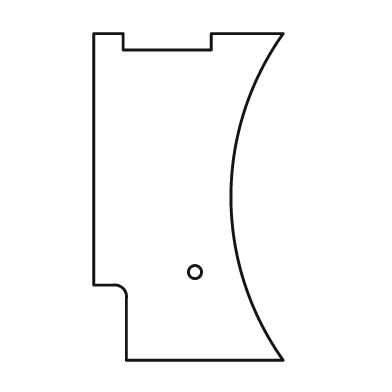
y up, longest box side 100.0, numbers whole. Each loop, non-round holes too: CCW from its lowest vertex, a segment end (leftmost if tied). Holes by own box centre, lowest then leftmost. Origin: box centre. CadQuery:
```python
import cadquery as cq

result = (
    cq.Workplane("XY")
    .moveTo(-19.0, -50.0)
    .lineTo(29.0, -50.0)
    .threePointArc((13.0, 0.0), (29.0, 50.0))
    .lineTo(7.0, 50.0)
    .lineTo(7.0, 45.0)
    .lineTo(-20.0, 45.0)
    .lineTo(-20.0, 50.0)
    .lineTo(-29.0, 50.0)
    .lineTo(-29.0, -27.0)
    .lineTo(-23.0, -27.0)
    .threePointArc((-20.0, -28.0), (-19.0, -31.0))
    .close()
    .moveTo(2.0, -23.0)
    .circle(2.0)
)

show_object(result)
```